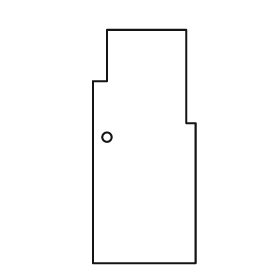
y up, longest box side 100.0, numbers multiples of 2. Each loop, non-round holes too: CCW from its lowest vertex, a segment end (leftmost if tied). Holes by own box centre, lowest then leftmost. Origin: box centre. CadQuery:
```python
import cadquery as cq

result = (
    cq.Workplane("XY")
    .moveTo(-22.0, -50.0)
    .lineTo(22.0, -50.0)
    .lineTo(22.0, 10.0)
    .lineTo(18.0, 10.0)
    .lineTo(18.0, 50.0)
    .lineTo(-16.0, 50.0)
    .lineTo(-16.0, 28.0)
    .lineTo(-22.0, 28.0)
    .close()
    .moveTo(-16.0, 4.0)
    .circle(2.0)
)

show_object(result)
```